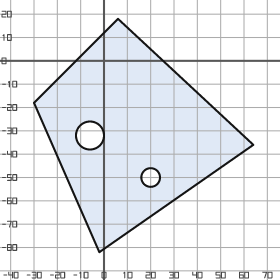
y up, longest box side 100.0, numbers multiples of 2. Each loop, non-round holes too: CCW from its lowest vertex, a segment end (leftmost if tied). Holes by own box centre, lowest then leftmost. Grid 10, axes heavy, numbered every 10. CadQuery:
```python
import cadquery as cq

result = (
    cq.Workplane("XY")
    .moveTo(-2.0, -82.0)
    .lineTo(64.0, -36.0)
    .lineTo(6.0, 18.0)
    .lineTo(-30.0, -18.0)
    .close()
    .moveTo(20.0, -50.0)
    .circle(4.0)
    .moveTo(-6.0, -32.0)
    .circle(6.0)
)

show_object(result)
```